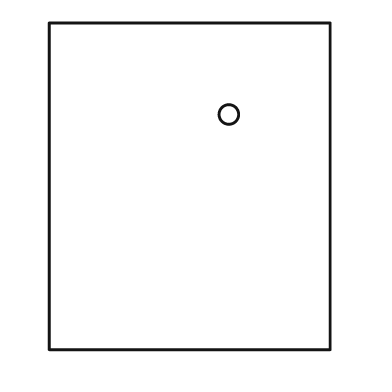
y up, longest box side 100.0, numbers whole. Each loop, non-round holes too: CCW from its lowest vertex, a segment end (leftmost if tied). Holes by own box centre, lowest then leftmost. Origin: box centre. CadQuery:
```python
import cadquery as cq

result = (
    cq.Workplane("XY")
    .moveTo(-43.0, -50.0)
    .lineTo(43.0, -50.0)
    .lineTo(43.0, 50.0)
    .lineTo(-43.0, 50.0)
    .close()
    .moveTo(12.0, 22.0)
    .circle(3.0)
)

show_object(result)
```